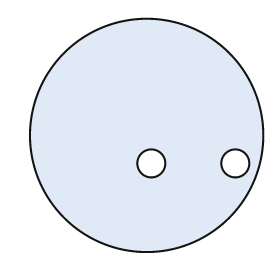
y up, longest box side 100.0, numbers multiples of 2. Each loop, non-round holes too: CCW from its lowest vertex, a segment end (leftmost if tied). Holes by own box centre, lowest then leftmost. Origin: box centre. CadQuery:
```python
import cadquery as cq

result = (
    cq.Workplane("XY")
    .moveTo(0.0, 0.0)
    .circle(50.0)
    .moveTo(2.0, -12.0)
    .circle(6.0)
    .moveTo(38.0, -12.0)
    .circle(6.0)
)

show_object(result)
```